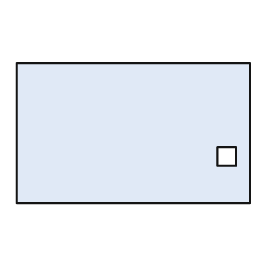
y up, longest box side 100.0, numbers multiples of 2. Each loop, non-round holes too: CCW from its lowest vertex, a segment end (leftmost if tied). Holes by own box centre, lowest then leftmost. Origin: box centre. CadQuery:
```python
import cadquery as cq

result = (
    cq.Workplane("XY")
    .moveTo(-50.0, -30.0)
    .lineTo(50.0, -30.0)
    .lineTo(50.0, 30.0)
    .lineTo(-50.0, 30.0)
    .close()
    .moveTo(36.0, -14.0)
    .lineTo(44.0, -14.0)
    .lineTo(44.0, -6.0)
    .lineTo(36.0, -6.0)
    .close()
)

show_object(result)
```